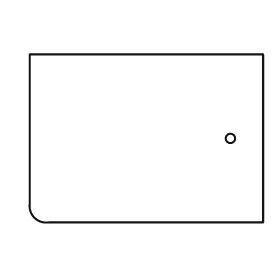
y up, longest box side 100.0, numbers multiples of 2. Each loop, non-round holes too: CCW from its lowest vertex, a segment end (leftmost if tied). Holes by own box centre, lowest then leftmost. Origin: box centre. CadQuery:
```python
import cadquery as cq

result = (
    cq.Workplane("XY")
    .moveTo(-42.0, -36.0)
    .lineTo(50.0, -36.0)
    .lineTo(50.0, 36.0)
    .lineTo(-50.0, 36.0)
    .lineTo(-50.0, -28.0)
    .threePointArc((-48.0, -34.0), (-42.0, -36.0))
    .close()
    .moveTo(36.0, 0.0)
    .circle(2.0)
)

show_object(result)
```